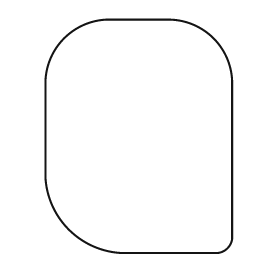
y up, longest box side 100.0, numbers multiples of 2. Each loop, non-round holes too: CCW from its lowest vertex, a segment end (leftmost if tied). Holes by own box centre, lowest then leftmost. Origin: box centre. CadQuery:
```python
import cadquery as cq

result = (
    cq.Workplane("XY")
    .moveTo(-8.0, -50.0)
    .lineTo(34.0, -50.0)
    .threePointArc((38.0, -48.0), (40.0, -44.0))
    .lineTo(40.0, 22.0)
    .threePointArc((32.0, 42.0), (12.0, 50.0))
    .lineTo(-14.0, 50.0)
    .threePointArc((-32.0, 42.0), (-40.0, 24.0))
    .lineTo(-40.0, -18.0)
    .threePointArc((-30.0, -40.0), (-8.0, -50.0))
    .close()
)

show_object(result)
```